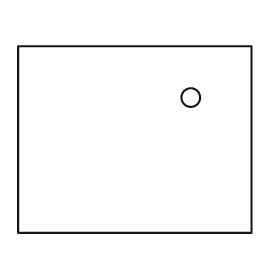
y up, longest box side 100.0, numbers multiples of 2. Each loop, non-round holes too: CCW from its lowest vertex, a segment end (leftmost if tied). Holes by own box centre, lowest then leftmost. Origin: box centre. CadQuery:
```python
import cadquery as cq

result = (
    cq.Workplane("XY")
    .moveTo(-50.0, -40.0)
    .lineTo(50.0, -40.0)
    .lineTo(50.0, 40.0)
    .lineTo(-50.0, 40.0)
    .close()
    .moveTo(24.0, 18.0)
    .circle(4.0)
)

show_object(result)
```